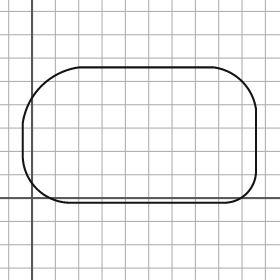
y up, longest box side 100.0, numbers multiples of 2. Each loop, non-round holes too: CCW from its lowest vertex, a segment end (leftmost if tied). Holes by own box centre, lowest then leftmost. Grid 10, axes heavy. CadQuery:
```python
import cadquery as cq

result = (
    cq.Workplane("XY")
    .moveTo(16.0, -2.0)
    .lineTo(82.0, -2.0)
    .threePointArc((92.0, 2.0), (96.0, 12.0))
    .lineTo(96.0, 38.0)
    .threePointArc((90.0, 50.0), (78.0, 56.0))
    .lineTo(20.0, 56.0)
    .threePointArc((4.0, 48.0), (-4.0, 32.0))
    .lineTo(-4.0, 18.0)
    .threePointArc((2.0, 4.0), (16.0, -2.0))
    .close()
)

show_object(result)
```